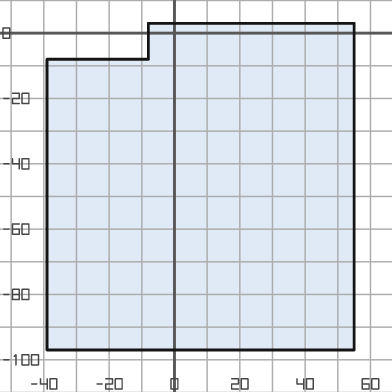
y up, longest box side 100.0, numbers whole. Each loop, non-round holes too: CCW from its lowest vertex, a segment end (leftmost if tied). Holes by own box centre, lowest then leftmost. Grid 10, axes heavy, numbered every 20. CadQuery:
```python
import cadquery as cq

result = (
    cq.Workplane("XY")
    .moveTo(-39.0, -97.0)
    .lineTo(55.0, -97.0)
    .lineTo(55.0, 3.0)
    .lineTo(-8.0, 3.0)
    .lineTo(-8.0, -8.0)
    .lineTo(-39.0, -8.0)
    .close()
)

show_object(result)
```